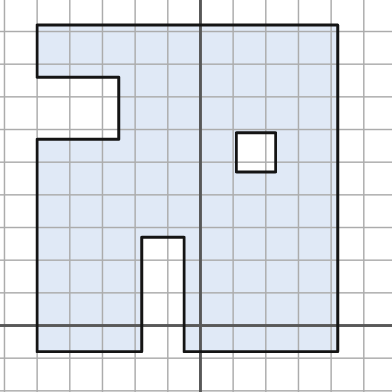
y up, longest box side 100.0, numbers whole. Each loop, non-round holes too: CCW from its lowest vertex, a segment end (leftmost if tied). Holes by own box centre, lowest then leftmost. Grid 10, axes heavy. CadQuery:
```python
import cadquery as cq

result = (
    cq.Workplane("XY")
    .moveTo(-50.0, -8.0)
    .lineTo(-18.0, -8.0)
    .lineTo(-18.0, 27.0)
    .lineTo(-5.0, 27.0)
    .lineTo(-5.0, -8.0)
    .lineTo(42.0, -8.0)
    .lineTo(42.0, 92.0)
    .lineTo(-50.0, 92.0)
    .lineTo(-50.0, 76.0)
    .lineTo(-25.0, 76.0)
    .lineTo(-25.0, 57.0)
    .lineTo(-50.0, 57.0)
    .close()
    .moveTo(11.0, 47.0)
    .lineTo(23.0, 47.0)
    .lineTo(23.0, 59.0)
    .lineTo(11.0, 59.0)
    .close()
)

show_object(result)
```